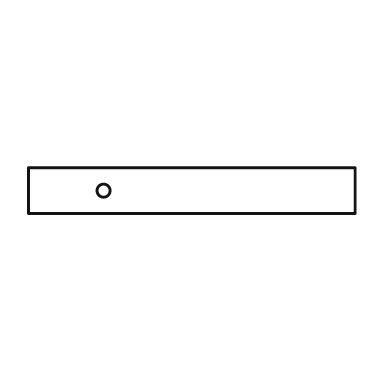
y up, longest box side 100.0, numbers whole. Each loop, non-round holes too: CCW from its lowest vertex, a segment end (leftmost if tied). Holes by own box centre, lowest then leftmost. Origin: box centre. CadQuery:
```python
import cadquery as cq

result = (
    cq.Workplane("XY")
    .moveTo(-50.0, -7.0)
    .lineTo(50.0, -7.0)
    .lineTo(50.0, 7.0)
    .lineTo(-50.0, 7.0)
    .close()
    .moveTo(-27.0, 0.0)
    .circle(2.0)
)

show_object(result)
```